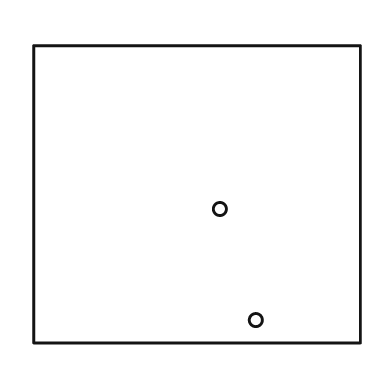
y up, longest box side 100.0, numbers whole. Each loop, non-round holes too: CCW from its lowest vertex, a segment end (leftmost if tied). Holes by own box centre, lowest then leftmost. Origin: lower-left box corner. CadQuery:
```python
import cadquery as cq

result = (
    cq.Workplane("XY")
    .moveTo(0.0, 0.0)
    .lineTo(100.0, 0.0)
    .lineTo(100.0, 91.0)
    .lineTo(0.0, 91.0)
    .close()
    .moveTo(68.0, 7.0)
    .circle(2.0)
    .moveTo(57.0, 41.0)
    .circle(2.0)
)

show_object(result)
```